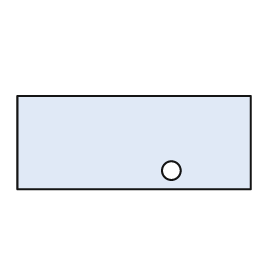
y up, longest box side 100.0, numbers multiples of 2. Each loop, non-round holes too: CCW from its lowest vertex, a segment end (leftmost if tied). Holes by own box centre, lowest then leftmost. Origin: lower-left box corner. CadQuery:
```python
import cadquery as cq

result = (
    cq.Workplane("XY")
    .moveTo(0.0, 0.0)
    .lineTo(100.0, 0.0)
    .lineTo(100.0, 40.0)
    .lineTo(0.0, 40.0)
    .close()
    .moveTo(66.0, 8.0)
    .circle(4.0)
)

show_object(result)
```